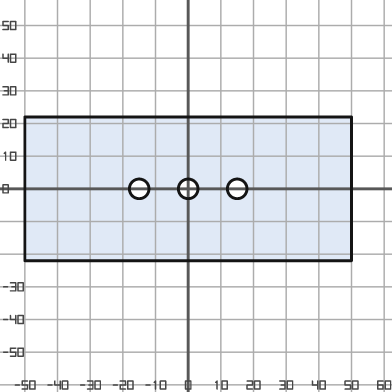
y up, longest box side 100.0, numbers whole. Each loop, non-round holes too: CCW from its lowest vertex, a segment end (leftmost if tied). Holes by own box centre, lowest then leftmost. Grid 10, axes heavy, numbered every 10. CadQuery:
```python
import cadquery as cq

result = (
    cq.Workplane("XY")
    .moveTo(-50.0, -22.0)
    .lineTo(50.0, -22.0)
    .lineTo(50.0, 22.0)
    .lineTo(-50.0, 22.0)
    .close()
    .moveTo(-15.0, 0.0)
    .circle(3.0)
    .moveTo(0.0, 0.0)
    .circle(3.0)
    .moveTo(15.0, 0.0)
    .circle(3.0)
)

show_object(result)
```